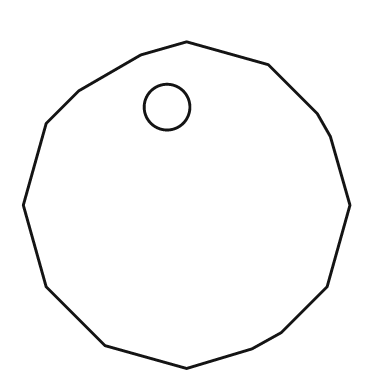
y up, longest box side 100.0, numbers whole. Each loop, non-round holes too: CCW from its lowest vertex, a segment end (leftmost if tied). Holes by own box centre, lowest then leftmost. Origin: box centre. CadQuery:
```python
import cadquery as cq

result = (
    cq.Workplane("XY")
    .moveTo(0.0, -50.0)
    .lineTo(20.0, -44.0)
    .lineTo(29.0, -39.0)
    .lineTo(43.0, -25.0)
    .lineTo(50.0, 0.0)
    .lineTo(44.0, 21.0)
    .lineTo(40.0, 28.0)
    .lineTo(25.0, 43.0)
    .lineTo(0.0, 50.0)
    .lineTo(-14.0, 46.0)
    .lineTo(-33.0, 35.0)
    .lineTo(-43.0, 25.0)
    .lineTo(-50.0, 0.0)
    .lineTo(-43.0, -25.0)
    .lineTo(-25.0, -43.0)
    .close()
    .moveTo(-6.0, 30.0)
    .circle(7.0)
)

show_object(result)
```